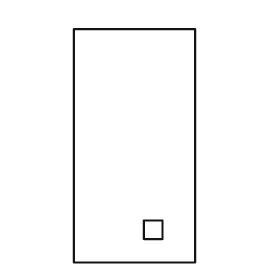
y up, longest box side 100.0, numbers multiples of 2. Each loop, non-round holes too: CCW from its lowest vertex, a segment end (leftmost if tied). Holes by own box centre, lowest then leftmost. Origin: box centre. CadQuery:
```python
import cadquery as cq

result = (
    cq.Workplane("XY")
    .moveTo(-26.0, -50.0)
    .lineTo(26.0, -50.0)
    .lineTo(26.0, 50.0)
    .lineTo(-26.0, 50.0)
    .close()
    .moveTo(4.0, -40.0)
    .lineTo(12.0, -40.0)
    .lineTo(12.0, -32.0)
    .lineTo(4.0, -32.0)
    .close()
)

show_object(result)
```